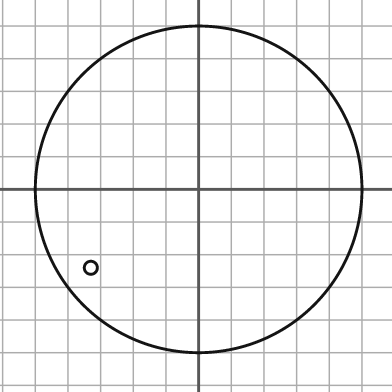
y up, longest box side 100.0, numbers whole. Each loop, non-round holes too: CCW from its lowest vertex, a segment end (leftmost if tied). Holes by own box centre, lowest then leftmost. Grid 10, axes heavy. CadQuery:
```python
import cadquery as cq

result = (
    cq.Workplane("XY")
    .moveTo(0.0, 0.0)
    .circle(50.0)
    .moveTo(-33.0, -24.0)
    .circle(2.0)
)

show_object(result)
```